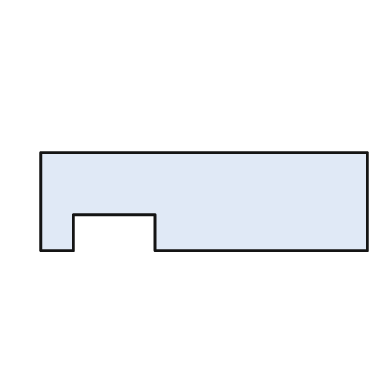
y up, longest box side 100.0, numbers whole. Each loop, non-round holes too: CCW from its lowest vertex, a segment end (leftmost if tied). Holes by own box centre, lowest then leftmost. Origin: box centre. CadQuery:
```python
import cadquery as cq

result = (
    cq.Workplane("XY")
    .moveTo(-50.0, -15.0)
    .lineTo(-40.0, -15.0)
    .lineTo(-40.0, -4.0)
    .lineTo(-15.0, -4.0)
    .lineTo(-15.0, -15.0)
    .lineTo(50.0, -15.0)
    .lineTo(50.0, 15.0)
    .lineTo(-50.0, 15.0)
    .close()
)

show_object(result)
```